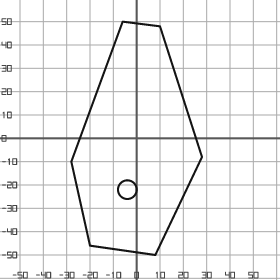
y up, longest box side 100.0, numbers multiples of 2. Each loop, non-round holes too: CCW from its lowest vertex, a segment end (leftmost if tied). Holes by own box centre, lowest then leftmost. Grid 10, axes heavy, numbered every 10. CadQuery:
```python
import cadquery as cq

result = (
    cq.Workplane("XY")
    .moveTo(8.0, -50.0)
    .lineTo(28.0, -8.0)
    .lineTo(10.0, 48.0)
    .lineTo(-6.0, 50.0)
    .lineTo(-28.0, -10.0)
    .lineTo(-20.0, -46.0)
    .close()
    .moveTo(-4.0, -22.0)
    .circle(4.0)
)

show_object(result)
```